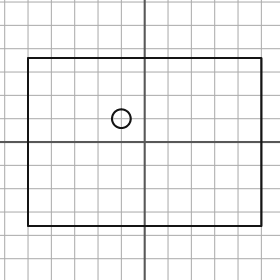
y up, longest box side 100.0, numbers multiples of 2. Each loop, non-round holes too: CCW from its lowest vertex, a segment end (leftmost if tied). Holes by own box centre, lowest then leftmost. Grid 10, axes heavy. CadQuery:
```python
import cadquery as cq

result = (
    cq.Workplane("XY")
    .moveTo(-50.0, -36.0)
    .lineTo(50.0, -36.0)
    .lineTo(50.0, 36.0)
    .lineTo(-50.0, 36.0)
    .close()
    .moveTo(-10.0, 10.0)
    .circle(4.0)
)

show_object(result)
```